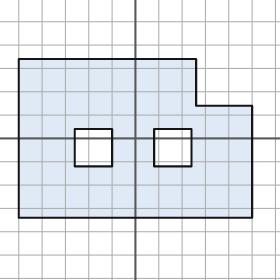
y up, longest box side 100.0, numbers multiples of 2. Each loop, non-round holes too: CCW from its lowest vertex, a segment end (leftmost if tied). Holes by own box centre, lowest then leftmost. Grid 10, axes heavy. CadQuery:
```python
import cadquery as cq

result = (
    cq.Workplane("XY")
    .moveTo(-50.0, -34.0)
    .lineTo(50.0, -34.0)
    .lineTo(50.0, 14.0)
    .lineTo(26.0, 14.0)
    .lineTo(26.0, 34.0)
    .lineTo(-50.0, 34.0)
    .close()
    .moveTo(-26.0, -12.0)
    .lineTo(-10.0, -12.0)
    .lineTo(-10.0, 4.0)
    .lineTo(-26.0, 4.0)
    .close()
    .moveTo(8.0, -12.0)
    .lineTo(24.0, -12.0)
    .lineTo(24.0, 4.0)
    .lineTo(8.0, 4.0)
    .close()
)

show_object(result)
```